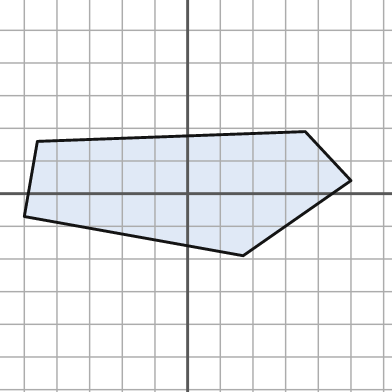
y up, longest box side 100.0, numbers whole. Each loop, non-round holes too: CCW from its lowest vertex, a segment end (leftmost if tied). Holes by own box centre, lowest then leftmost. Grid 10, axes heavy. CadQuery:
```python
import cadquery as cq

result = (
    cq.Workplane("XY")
    .moveTo(17.0, -19.0)
    .lineTo(50.0, 4.0)
    .lineTo(36.0, 19.0)
    .lineTo(-46.0, 16.0)
    .lineTo(-50.0, -7.0)
    .close()
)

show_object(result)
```